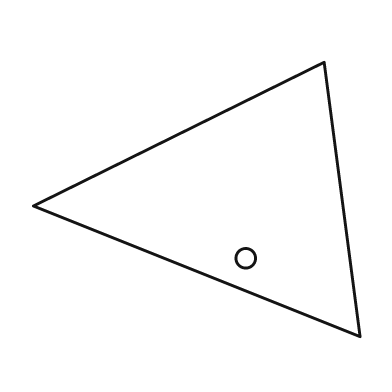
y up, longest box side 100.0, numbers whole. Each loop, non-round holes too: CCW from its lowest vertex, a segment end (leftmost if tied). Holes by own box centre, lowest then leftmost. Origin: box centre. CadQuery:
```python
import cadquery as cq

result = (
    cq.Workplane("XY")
    .moveTo(50.0, -42.0)
    .lineTo(39.0, 42.0)
    .lineTo(-50.0, -2.0)
    .close()
    .moveTo(15.0, -18.0)
    .circle(3.0)
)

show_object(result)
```